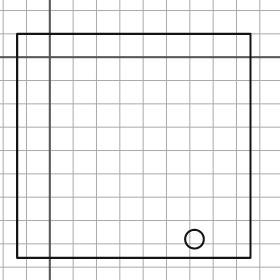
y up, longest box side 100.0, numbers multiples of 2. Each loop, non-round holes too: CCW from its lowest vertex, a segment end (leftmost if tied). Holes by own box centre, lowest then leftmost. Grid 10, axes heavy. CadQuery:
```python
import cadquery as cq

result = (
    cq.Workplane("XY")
    .moveTo(-14.0, -86.0)
    .lineTo(86.0, -86.0)
    .lineTo(86.0, 10.0)
    .lineTo(-14.0, 10.0)
    .close()
    .moveTo(62.0, -78.0)
    .circle(4.0)
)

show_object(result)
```